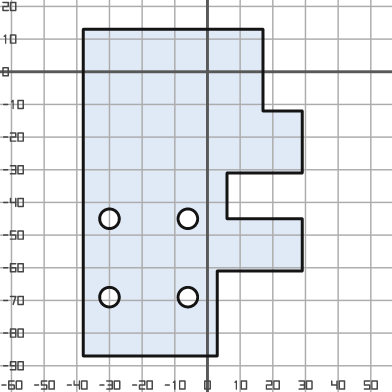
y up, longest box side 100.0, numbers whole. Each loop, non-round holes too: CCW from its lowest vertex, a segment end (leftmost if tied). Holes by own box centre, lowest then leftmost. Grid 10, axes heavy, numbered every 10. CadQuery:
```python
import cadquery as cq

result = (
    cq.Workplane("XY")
    .moveTo(-38.0, -87.0)
    .lineTo(3.0, -87.0)
    .lineTo(3.0, -61.0)
    .lineTo(29.0, -61.0)
    .lineTo(29.0, -45.0)
    .lineTo(6.0, -45.0)
    .lineTo(6.0, -31.0)
    .lineTo(29.0, -31.0)
    .lineTo(29.0, -12.0)
    .lineTo(17.0, -12.0)
    .lineTo(17.0, 13.0)
    .lineTo(-38.0, 13.0)
    .close()
    .moveTo(-30.0, -69.0)
    .circle(3.0)
    .moveTo(-6.0, -69.0)
    .circle(3.0)
    .moveTo(-30.0, -45.0)
    .circle(3.0)
    .moveTo(-6.0, -45.0)
    .circle(3.0)
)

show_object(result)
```